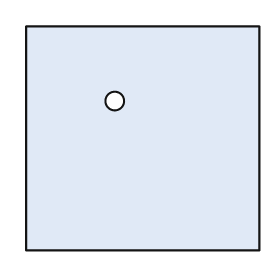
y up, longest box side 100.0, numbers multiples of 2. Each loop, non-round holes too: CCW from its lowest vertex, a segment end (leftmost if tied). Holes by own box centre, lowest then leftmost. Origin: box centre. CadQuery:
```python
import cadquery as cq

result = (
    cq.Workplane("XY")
    .moveTo(-50.0, -48.0)
    .lineTo(50.0, -48.0)
    .lineTo(50.0, 48.0)
    .lineTo(-50.0, 48.0)
    .close()
    .moveTo(-12.0, 16.0)
    .circle(4.0)
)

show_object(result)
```